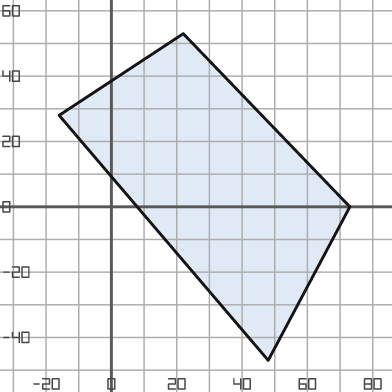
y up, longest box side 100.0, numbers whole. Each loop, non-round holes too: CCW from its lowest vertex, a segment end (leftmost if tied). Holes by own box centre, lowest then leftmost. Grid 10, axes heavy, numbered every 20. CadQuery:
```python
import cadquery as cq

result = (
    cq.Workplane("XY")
    .moveTo(48.0, -47.0)
    .lineTo(73.0, 0.0)
    .lineTo(22.0, 53.0)
    .lineTo(-16.0, 28.0)
    .close()
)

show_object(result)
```